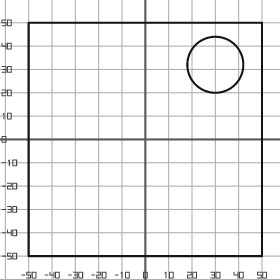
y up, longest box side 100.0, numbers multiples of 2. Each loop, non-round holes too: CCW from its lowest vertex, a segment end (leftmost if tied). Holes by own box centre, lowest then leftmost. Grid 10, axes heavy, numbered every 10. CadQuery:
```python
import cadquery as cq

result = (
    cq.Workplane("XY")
    .moveTo(-50.0, -50.0)
    .lineTo(50.0, -50.0)
    .lineTo(50.0, 50.0)
    .lineTo(-50.0, 50.0)
    .close()
    .moveTo(30.0, 32.0)
    .circle(12.0)
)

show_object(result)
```